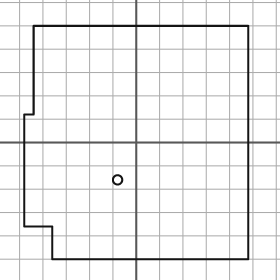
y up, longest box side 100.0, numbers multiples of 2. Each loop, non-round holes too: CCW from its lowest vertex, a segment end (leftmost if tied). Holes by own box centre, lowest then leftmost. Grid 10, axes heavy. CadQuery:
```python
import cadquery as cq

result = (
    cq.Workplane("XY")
    .moveTo(-36.0, -50.0)
    .lineTo(48.0, -50.0)
    .lineTo(48.0, 50.0)
    .lineTo(-44.0, 50.0)
    .lineTo(-44.0, 12.0)
    .lineTo(-48.0, 12.0)
    .lineTo(-48.0, -36.0)
    .lineTo(-36.0, -36.0)
    .close()
    .moveTo(-8.0, -16.0)
    .circle(2.0)
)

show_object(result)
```